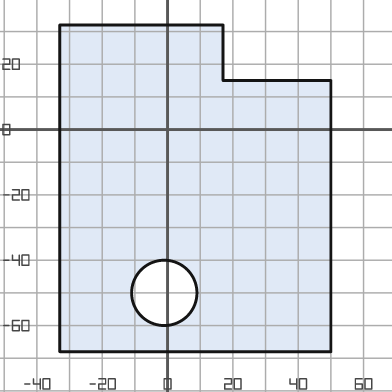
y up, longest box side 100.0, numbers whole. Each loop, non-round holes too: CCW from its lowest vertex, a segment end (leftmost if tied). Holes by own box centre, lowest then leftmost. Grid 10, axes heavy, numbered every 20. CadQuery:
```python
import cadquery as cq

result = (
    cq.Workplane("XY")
    .moveTo(-33.0, -68.0)
    .lineTo(50.0, -68.0)
    .lineTo(50.0, 15.0)
    .lineTo(17.0, 15.0)
    .lineTo(17.0, 32.0)
    .lineTo(-33.0, 32.0)
    .close()
    .moveTo(-1.0, -50.0)
    .circle(10.0)
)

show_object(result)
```